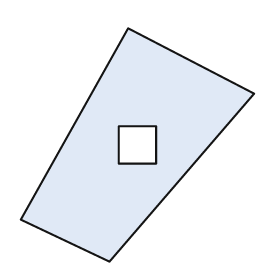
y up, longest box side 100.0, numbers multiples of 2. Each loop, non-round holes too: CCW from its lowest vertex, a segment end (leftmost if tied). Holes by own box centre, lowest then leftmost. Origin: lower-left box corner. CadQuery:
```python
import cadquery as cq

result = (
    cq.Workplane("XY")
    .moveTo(38.0, 0.0)
    .lineTo(100.0, 72.0)
    .lineTo(46.0, 100.0)
    .lineTo(0.0, 18.0)
    .close()
    .moveTo(42.0, 42.0)
    .lineTo(58.0, 42.0)
    .lineTo(58.0, 58.0)
    .lineTo(42.0, 58.0)
    .close()
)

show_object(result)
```